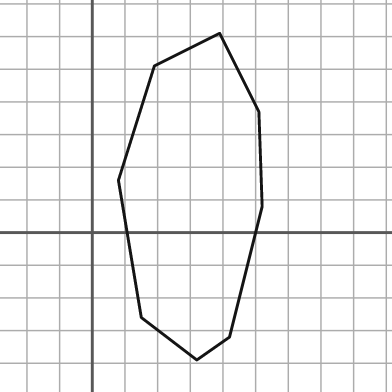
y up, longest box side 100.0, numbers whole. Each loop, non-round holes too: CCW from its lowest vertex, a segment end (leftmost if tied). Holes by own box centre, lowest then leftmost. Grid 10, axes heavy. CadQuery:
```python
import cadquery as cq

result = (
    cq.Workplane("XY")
    .moveTo(32.0, -39.0)
    .lineTo(42.0, -32.0)
    .lineTo(52.0, 8.0)
    .lineTo(51.0, 37.0)
    .lineTo(39.0, 61.0)
    .lineTo(19.0, 51.0)
    .lineTo(8.0, 16.0)
    .lineTo(15.0, -26.0)
    .close()
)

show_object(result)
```